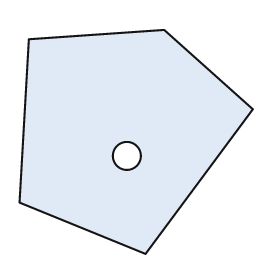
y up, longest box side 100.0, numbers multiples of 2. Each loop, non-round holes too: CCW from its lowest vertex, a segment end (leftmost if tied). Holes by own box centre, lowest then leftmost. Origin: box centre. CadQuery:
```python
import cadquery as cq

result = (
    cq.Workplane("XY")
    .moveTo(4.0, -48.0)
    .lineTo(50.0, 14.0)
    .lineTo(12.0, 48.0)
    .lineTo(-46.0, 44.0)
    .lineTo(-50.0, -26.0)
    .close()
    .moveTo(-4.0, -6.0)
    .circle(6.0)
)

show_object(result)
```